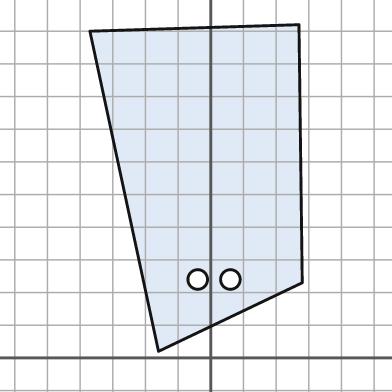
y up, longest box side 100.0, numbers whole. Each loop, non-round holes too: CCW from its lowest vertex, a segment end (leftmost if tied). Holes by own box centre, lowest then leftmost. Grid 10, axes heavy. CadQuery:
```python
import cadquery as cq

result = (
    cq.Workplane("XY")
    .moveTo(-16.0, 2.0)
    .lineTo(28.0, 23.0)
    .lineTo(27.0, 102.0)
    .lineTo(-37.0, 100.0)
    .close()
    .moveTo(-4.0, 24.0)
    .circle(3.0)
    .moveTo(6.0, 24.0)
    .circle(3.0)
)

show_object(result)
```